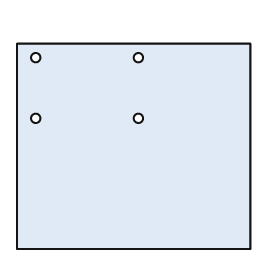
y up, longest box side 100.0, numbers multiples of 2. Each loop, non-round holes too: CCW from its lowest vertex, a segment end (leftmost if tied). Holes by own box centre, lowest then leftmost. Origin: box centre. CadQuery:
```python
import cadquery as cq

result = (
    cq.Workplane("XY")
    .moveTo(-50.0, -44.0)
    .lineTo(50.0, -44.0)
    .lineTo(50.0, 44.0)
    .lineTo(-50.0, 44.0)
    .close()
    .moveTo(-42.0, 12.0)
    .circle(2.0)
    .moveTo(2.0, 12.0)
    .circle(2.0)
    .moveTo(-42.0, 38.0)
    .circle(2.0)
    .moveTo(2.0, 38.0)
    .circle(2.0)
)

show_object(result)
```